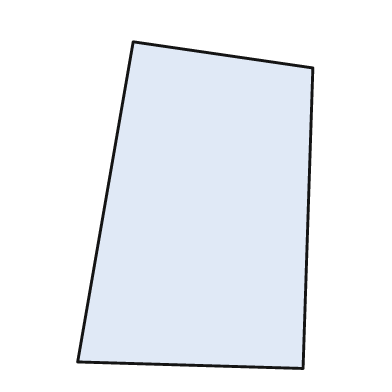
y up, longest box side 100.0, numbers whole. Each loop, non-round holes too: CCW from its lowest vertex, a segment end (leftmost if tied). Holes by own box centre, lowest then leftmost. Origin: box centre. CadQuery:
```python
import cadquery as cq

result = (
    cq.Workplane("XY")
    .moveTo(33.0, -50.0)
    .lineTo(36.0, 42.0)
    .lineTo(-19.0, 50.0)
    .lineTo(-36.0, -48.0)
    .close()
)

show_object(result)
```